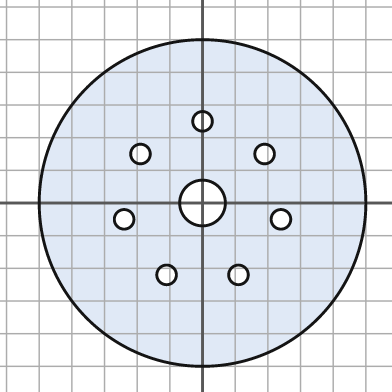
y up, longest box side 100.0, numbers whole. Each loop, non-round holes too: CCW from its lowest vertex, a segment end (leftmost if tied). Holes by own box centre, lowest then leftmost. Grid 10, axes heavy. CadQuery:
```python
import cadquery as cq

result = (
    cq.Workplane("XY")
    .moveTo(0.0, 0.0)
    .circle(50.0)
    .moveTo(-11.0, -22.0)
    .circle(3.0)
    .moveTo(11.0, -22.0)
    .circle(3.0)
    .moveTo(-24.0, -5.0)
    .circle(3.0)
    .moveTo(24.0, -5.0)
    .circle(3.0)
    .moveTo(0.0, 0.0)
    .circle(7.0)
    .moveTo(-19.0, 15.0)
    .circle(3.0)
    .moveTo(19.0, 15.0)
    .circle(3.0)
    .moveTo(0.0, 25.0)
    .circle(3.0)
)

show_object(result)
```